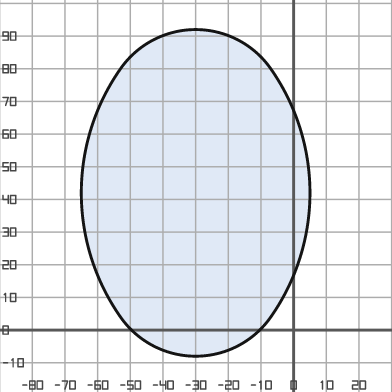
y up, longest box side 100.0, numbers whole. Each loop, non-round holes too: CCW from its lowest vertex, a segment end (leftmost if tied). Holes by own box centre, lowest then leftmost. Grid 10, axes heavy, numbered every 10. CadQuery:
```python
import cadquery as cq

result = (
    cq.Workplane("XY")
    .moveTo(-53.0, 4.0)
    .threePointArc((-30.0, -8.0), (-7.0, 4.0))
    .threePointArc((5.0, 42.0), (-7.0, 80.0))
    .threePointArc((-30.0, 92.0), (-53.0, 80.0))
    .threePointArc((-65.0, 42.0), (-53.0, 4.0))
    .close()
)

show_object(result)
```